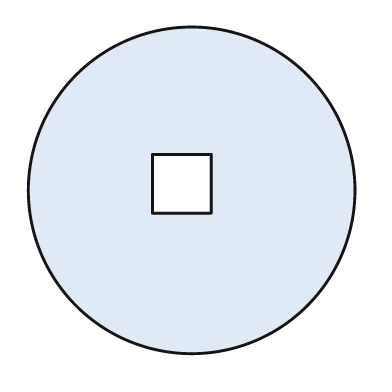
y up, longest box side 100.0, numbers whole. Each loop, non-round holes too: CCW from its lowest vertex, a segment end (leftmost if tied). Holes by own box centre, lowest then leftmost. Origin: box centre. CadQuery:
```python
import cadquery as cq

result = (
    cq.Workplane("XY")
    .moveTo(0.0, 0.0)
    .circle(50.0)
    .moveTo(-12.0, -7.0)
    .lineTo(6.0, -7.0)
    .lineTo(6.0, 11.0)
    .lineTo(-12.0, 11.0)
    .close()
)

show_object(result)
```